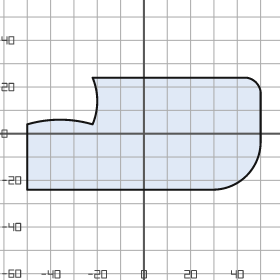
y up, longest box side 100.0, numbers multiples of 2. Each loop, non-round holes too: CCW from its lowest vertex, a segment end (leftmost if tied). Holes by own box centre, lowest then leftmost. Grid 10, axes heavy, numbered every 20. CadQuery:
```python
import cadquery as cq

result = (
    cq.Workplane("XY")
    .moveTo(-50.0, -24.0)
    .lineTo(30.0, -24.0)
    .threePointArc((44.0, -18.0), (50.0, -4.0))
    .lineTo(50.0, 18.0)
    .threePointArc((48.0, 22.0), (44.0, 24.0))
    .lineTo(-22.0, 24.0)
    .threePointArc((-20.0, 14.0), (-22.0, 4.0))
    .threePointArc((-36.0, 6.0), (-50.0, 4.0))
    .close()
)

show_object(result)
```